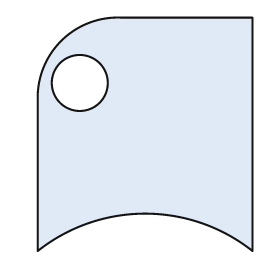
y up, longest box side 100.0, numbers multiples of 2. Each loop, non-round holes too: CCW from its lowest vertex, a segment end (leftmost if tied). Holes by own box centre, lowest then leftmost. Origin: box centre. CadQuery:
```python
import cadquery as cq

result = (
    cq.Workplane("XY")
    .moveTo(-46.0, -50.0)
    .threePointArc((0.0, -34.0), (46.0, -50.0))
    .lineTo(46.0, 50.0)
    .lineTo(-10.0, 50.0)
    .threePointArc((-36.0, 40.0), (-46.0, 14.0))
    .close()
    .moveTo(-28.0, 22.0)
    .circle(12.0)
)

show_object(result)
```